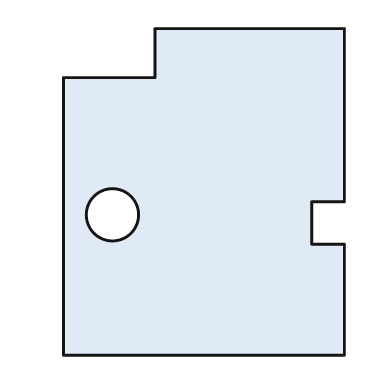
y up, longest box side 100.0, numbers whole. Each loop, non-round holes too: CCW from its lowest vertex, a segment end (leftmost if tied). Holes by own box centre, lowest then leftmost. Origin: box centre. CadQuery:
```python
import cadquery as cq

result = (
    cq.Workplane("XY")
    .moveTo(-43.0, -50.0)
    .lineTo(43.0, -50.0)
    .lineTo(43.0, -16.0)
    .lineTo(33.0, -16.0)
    .lineTo(33.0, -3.0)
    .lineTo(43.0, -3.0)
    .lineTo(43.0, 50.0)
    .lineTo(-15.0, 50.0)
    .lineTo(-15.0, 35.0)
    .lineTo(-43.0, 35.0)
    .close()
    .moveTo(-28.0, -7.0)
    .circle(8.0)
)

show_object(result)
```